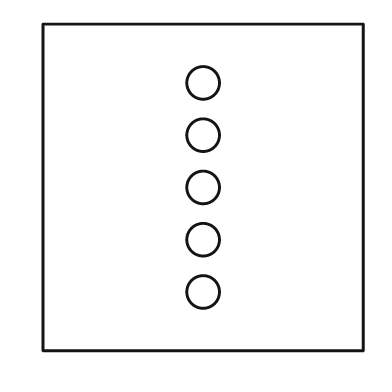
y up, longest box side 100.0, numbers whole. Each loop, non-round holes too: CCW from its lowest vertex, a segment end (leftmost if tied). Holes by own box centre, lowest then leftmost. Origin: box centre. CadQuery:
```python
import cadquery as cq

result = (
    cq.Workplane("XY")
    .moveTo(-49.0, -50.0)
    .lineTo(49.0, -50.0)
    .lineTo(49.0, 50.0)
    .lineTo(-49.0, 50.0)
    .close()
    .moveTo(0.0, -32.0)
    .circle(5.0)
    .moveTo(0.0, -16.0)
    .circle(5.0)
    .moveTo(0.0, 0.0)
    .circle(5.0)
    .moveTo(0.0, 16.0)
    .circle(5.0)
    .moveTo(0.0, 32.0)
    .circle(5.0)
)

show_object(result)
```